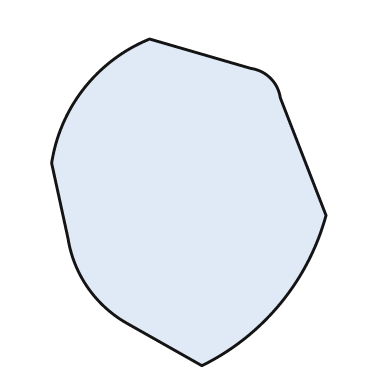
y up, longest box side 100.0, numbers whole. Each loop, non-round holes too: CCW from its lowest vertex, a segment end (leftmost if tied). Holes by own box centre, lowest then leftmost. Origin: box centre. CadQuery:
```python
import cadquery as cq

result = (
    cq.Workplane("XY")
    .moveTo(4.0, -50.0)
    .threePointArc((28.0, -31.0), (42.0, -4.0))
    .lineTo(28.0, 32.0)
    .threePointArc((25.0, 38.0), (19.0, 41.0))
    .lineTo(-12.0, 50.0)
    .threePointArc((-32.0, 35.0), (-42.0, 12.0))
    .lineTo(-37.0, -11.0)
    .threePointArc((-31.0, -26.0), (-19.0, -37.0))
    .close()
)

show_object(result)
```